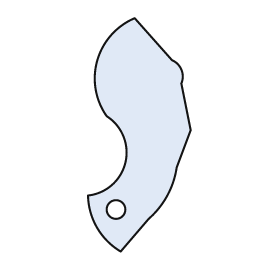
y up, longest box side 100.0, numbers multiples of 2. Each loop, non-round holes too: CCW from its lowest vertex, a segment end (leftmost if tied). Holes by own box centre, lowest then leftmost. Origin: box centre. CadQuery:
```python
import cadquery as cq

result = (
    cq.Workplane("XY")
    .moveTo(-8.0, -50.0)
    .lineTo(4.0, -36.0)
    .threePointArc((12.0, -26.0), (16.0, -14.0))
    .lineTo(22.0, 2.0)
    .lineTo(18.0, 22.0)
    .threePointArc((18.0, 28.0), (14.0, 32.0))
    .lineTo(-2.0, 50.0)
    .threePointArc((-18.0, 32.0), (-14.0, 8.0))
    .threePointArc((-6.0, -12.0), (-22.0, -26.0))
    .threePointArc((-18.0, -40.0), (-8.0, -50.0))
    .close()
    .moveTo(-10.0, -32.0)
    .circle(4.0)
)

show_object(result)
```